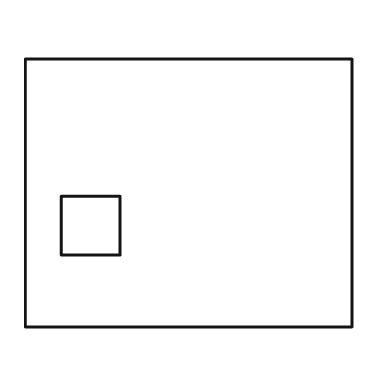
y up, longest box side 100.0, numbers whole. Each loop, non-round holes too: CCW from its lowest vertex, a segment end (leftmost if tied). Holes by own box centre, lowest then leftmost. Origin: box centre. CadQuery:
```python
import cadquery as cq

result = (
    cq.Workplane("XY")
    .moveTo(-50.0, -41.0)
    .lineTo(50.0, -41.0)
    .lineTo(50.0, 41.0)
    .lineTo(-50.0, 41.0)
    .close()
    .moveTo(-39.0, -19.0)
    .lineTo(-21.0, -19.0)
    .lineTo(-21.0, -1.0)
    .lineTo(-39.0, -1.0)
    .close()
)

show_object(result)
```